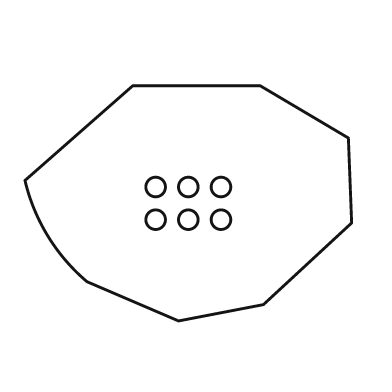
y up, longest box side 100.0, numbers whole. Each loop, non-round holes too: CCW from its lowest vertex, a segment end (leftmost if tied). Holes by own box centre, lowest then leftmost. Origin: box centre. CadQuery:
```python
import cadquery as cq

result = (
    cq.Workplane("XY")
    .moveTo(-3.0, -36.0)
    .lineTo(23.0, -31.0)
    .lineTo(50.0, -6.0)
    .lineTo(49.0, 20.0)
    .lineTo(22.0, 36.0)
    .lineTo(-17.0, 36.0)
    .lineTo(-50.0, 7.0)
    .threePointArc((-43.0, -10.0), (-31.0, -24.0))
    .close()
    .moveTo(-10.0, -5.0)
    .circle(3.0)
    .moveTo(0.0, -5.0)
    .circle(3.0)
    .moveTo(10.0, -5.0)
    .circle(3.0)
    .moveTo(-10.0, 5.0)
    .circle(3.0)
    .moveTo(0.0, 5.0)
    .circle(3.0)
    .moveTo(10.0, 5.0)
    .circle(3.0)
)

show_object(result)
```